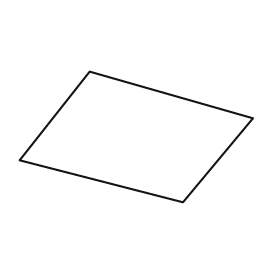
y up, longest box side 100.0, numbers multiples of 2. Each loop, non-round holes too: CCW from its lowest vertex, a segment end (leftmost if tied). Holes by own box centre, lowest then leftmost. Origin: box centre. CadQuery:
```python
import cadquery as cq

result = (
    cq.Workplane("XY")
    .moveTo(20.0, -28.0)
    .lineTo(50.0, 8.0)
    .lineTo(-20.0, 28.0)
    .lineTo(-50.0, -10.0)
    .close()
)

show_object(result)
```